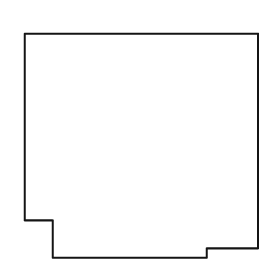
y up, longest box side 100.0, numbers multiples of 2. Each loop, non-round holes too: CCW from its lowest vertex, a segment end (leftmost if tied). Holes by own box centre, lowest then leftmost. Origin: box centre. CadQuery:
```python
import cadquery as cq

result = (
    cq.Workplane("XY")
    .moveTo(-38.0, -48.0)
    .lineTo(28.0, -48.0)
    .lineTo(28.0, -44.0)
    .lineTo(50.0, -44.0)
    .lineTo(50.0, 48.0)
    .lineTo(-50.0, 48.0)
    .lineTo(-50.0, -32.0)
    .lineTo(-38.0, -32.0)
    .close()
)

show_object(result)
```